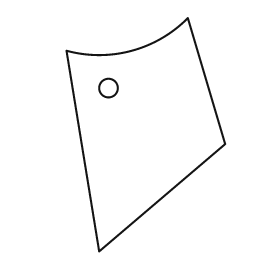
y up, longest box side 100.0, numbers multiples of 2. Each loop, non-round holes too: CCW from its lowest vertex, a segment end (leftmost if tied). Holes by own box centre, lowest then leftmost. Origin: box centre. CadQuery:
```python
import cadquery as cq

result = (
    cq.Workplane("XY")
    .moveTo(-20.0, -50.0)
    .lineTo(34.0, -4.0)
    .lineTo(18.0, 50.0)
    .threePointArc((-6.0, 36.0), (-34.0, 36.0))
    .close()
    .moveTo(-16.0, 20.0)
    .circle(4.0)
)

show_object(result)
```